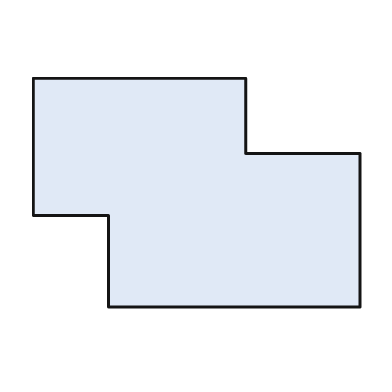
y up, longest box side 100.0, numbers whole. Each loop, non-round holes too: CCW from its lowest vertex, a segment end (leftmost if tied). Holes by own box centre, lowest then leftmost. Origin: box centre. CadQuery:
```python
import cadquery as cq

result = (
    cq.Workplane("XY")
    .moveTo(-27.0, -35.0)
    .lineTo(50.0, -35.0)
    .lineTo(50.0, 12.0)
    .lineTo(15.0, 12.0)
    .lineTo(15.0, 35.0)
    .lineTo(-50.0, 35.0)
    .lineTo(-50.0, -7.0)
    .lineTo(-27.0, -7.0)
    .close()
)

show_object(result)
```